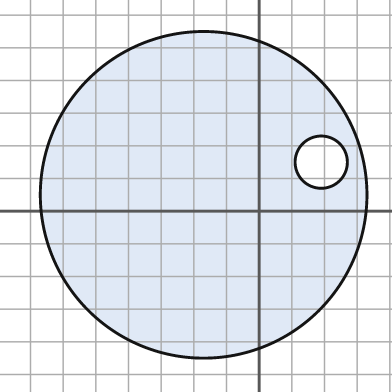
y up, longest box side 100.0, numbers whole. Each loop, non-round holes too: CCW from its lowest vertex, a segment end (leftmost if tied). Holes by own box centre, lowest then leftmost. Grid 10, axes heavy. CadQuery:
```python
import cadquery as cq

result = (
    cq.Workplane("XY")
    .moveTo(-17.0, 5.0)
    .circle(50.0)
    .moveTo(19.0, 15.0)
    .circle(8.0)
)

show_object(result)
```